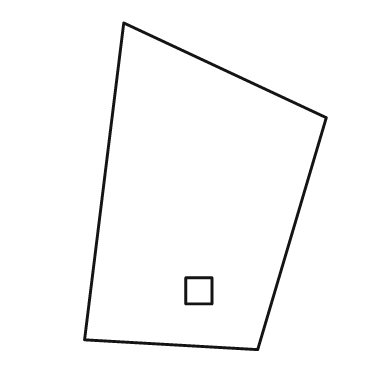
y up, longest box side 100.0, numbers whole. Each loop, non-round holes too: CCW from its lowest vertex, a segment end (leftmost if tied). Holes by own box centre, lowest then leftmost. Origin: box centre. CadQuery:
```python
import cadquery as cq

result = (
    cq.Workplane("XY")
    .moveTo(16.0, -50.0)
    .lineTo(37.0, 21.0)
    .lineTo(-25.0, 50.0)
    .lineTo(-37.0, -47.0)
    .close()
    .moveTo(-6.0, -36.0)
    .lineTo(2.0, -36.0)
    .lineTo(2.0, -28.0)
    .lineTo(-6.0, -28.0)
    .close()
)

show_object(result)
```